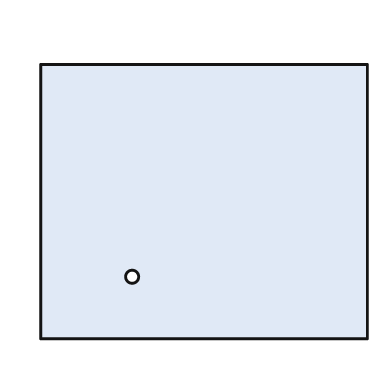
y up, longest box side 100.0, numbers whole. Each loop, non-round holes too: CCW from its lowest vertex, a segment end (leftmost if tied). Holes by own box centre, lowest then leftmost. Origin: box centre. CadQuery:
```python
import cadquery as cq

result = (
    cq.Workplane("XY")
    .moveTo(-50.0, -42.0)
    .lineTo(50.0, -42.0)
    .lineTo(50.0, 42.0)
    .lineTo(-50.0, 42.0)
    .close()
    .moveTo(-22.0, -23.0)
    .circle(2.0)
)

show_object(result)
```